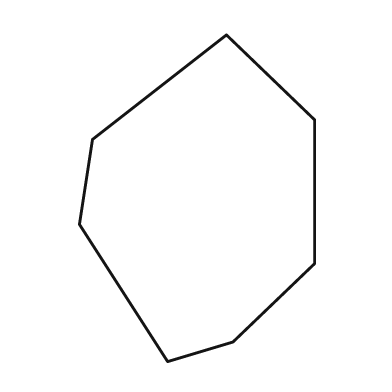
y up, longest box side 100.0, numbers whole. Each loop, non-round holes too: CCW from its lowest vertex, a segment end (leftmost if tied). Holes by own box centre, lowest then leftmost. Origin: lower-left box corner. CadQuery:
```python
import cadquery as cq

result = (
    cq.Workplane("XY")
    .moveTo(27.0, 0.0)
    .lineTo(47.0, 6.0)
    .lineTo(72.0, 30.0)
    .lineTo(72.0, 74.0)
    .lineTo(45.0, 100.0)
    .lineTo(4.0, 68.0)
    .lineTo(0.0, 42.0)
    .close()
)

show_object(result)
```